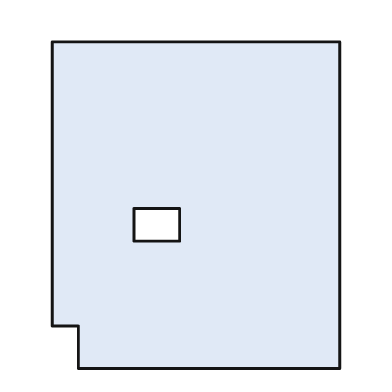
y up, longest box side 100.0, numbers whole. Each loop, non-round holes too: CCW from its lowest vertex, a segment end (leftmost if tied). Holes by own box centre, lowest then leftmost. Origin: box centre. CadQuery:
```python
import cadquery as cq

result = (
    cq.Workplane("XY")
    .moveTo(-36.0, -50.0)
    .lineTo(44.0, -50.0)
    .lineTo(44.0, 50.0)
    .lineTo(-44.0, 50.0)
    .lineTo(-44.0, -37.0)
    .lineTo(-36.0, -37.0)
    .close()
    .moveTo(-19.0, -11.0)
    .lineTo(-5.0, -11.0)
    .lineTo(-5.0, -1.0)
    .lineTo(-19.0, -1.0)
    .close()
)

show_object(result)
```